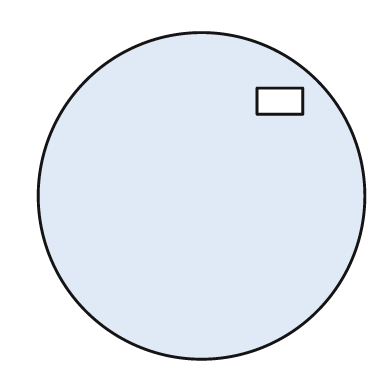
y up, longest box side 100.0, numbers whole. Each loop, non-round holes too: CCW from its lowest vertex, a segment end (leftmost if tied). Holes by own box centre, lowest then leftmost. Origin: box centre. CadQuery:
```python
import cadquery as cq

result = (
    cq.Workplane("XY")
    .moveTo(0.0, 0.0)
    .circle(50.0)
    .moveTo(17.0, 25.0)
    .lineTo(31.0, 25.0)
    .lineTo(31.0, 33.0)
    .lineTo(17.0, 33.0)
    .close()
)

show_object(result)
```